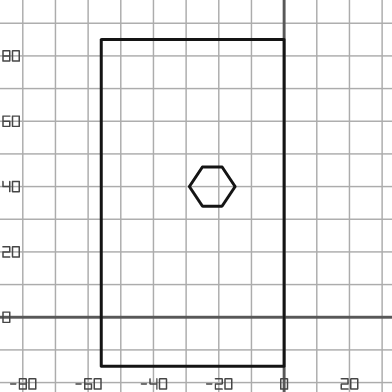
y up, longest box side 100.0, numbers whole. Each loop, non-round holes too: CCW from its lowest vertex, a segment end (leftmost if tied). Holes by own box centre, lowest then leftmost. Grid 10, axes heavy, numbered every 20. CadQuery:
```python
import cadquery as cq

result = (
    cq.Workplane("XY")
    .moveTo(-56.0, -15.0)
    .lineTo(0.0, -15.0)
    .lineTo(0.0, 85.0)
    .lineTo(-56.0, 85.0)
    .close()
    .moveTo(-25.0, 34.0)
    .lineTo(-19.0, 34.0)
    .lineTo(-15.0, 40.0)
    .lineTo(-19.0, 46.0)
    .lineTo(-25.0, 46.0)
    .lineTo(-29.0, 40.0)
    .close()
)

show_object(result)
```